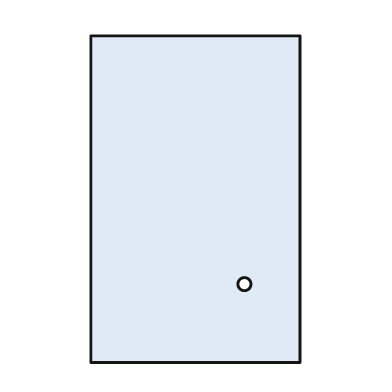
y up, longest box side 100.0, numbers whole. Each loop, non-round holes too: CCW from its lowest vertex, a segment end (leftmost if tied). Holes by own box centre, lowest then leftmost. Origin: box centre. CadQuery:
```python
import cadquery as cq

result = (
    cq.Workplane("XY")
    .moveTo(-32.0, -50.0)
    .lineTo(32.0, -50.0)
    .lineTo(32.0, 50.0)
    .lineTo(-32.0, 50.0)
    .close()
    .moveTo(15.0, -26.0)
    .circle(2.0)
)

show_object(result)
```